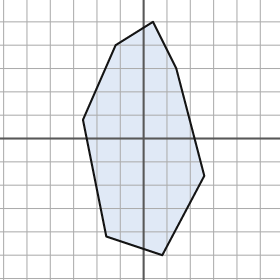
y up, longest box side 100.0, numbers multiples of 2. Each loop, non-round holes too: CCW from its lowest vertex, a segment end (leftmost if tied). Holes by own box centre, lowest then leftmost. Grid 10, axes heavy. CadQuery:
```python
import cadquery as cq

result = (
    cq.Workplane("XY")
    .moveTo(8.0, -50.0)
    .lineTo(26.0, -16.0)
    .lineTo(14.0, 30.0)
    .lineTo(4.0, 50.0)
    .lineTo(-12.0, 40.0)
    .lineTo(-26.0, 8.0)
    .lineTo(-16.0, -42.0)
    .close()
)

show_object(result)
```